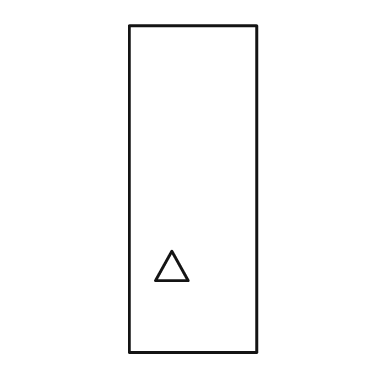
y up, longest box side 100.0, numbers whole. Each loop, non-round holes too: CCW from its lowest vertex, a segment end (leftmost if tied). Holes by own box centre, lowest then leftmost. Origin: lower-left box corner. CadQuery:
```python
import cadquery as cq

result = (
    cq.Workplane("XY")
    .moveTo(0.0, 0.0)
    .lineTo(39.0, 0.0)
    .lineTo(39.0, 100.0)
    .lineTo(0.0, 100.0)
    .close()
    .moveTo(8.0, 22.0)
    .lineTo(18.0, 22.0)
    .lineTo(13.0, 31.0)
    .close()
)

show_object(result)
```